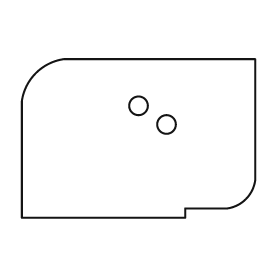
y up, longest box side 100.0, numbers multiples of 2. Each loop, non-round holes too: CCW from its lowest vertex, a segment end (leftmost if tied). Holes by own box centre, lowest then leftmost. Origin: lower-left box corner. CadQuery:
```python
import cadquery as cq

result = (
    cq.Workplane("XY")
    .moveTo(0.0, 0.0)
    .lineTo(70.0, 0.0)
    .lineTo(70.0, 4.0)
    .lineTo(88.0, 4.0)
    .threePointArc((96.0, 8.0), (100.0, 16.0))
    .lineTo(100.0, 68.0)
    .lineTo(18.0, 68.0)
    .threePointArc((6.0, 62.0), (0.0, 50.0))
    .close()
    .moveTo(62.0, 40.0)
    .circle(4.0)
    .moveTo(50.0, 48.0)
    .circle(4.0)
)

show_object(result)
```